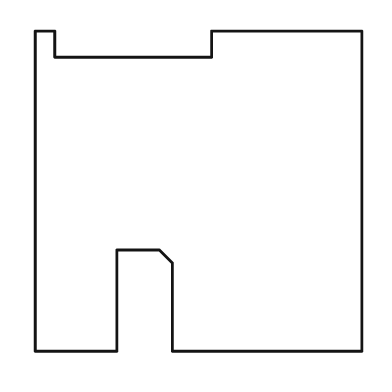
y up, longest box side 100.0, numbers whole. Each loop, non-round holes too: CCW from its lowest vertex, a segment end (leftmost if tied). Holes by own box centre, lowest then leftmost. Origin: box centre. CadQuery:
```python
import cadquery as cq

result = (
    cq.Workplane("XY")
    .moveTo(-50.0, -49.0)
    .lineTo(-25.0, -49.0)
    .lineTo(-25.0, -18.0)
    .lineTo(-12.0, -18.0)
    .lineTo(-8.0, -22.0)
    .lineTo(-8.0, -49.0)
    .lineTo(50.0, -49.0)
    .lineTo(50.0, 49.0)
    .lineTo(4.0, 49.0)
    .lineTo(4.0, 41.0)
    .lineTo(-44.0, 41.0)
    .lineTo(-44.0, 49.0)
    .lineTo(-50.0, 49.0)
    .close()
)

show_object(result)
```